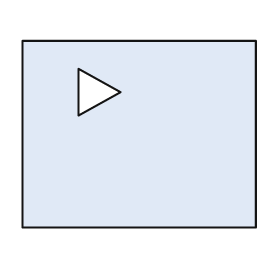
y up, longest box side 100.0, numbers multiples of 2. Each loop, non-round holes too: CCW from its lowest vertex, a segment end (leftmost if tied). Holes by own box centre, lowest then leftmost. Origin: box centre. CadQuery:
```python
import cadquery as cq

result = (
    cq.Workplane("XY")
    .moveTo(-50.0, -40.0)
    .lineTo(50.0, -40.0)
    .lineTo(50.0, 40.0)
    .lineTo(-50.0, 40.0)
    .close()
    .moveTo(-26.0, 8.0)
    .lineTo(-8.0, 18.0)
    .lineTo(-26.0, 28.0)
    .close()
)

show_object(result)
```